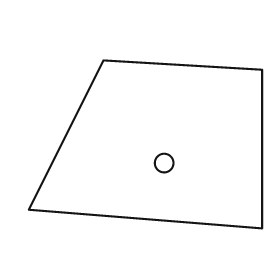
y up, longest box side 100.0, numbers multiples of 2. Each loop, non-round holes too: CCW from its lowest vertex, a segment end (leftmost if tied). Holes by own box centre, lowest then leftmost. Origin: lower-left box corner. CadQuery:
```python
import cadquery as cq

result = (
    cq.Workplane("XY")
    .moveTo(100.0, 0.0)
    .lineTo(100.0, 68.0)
    .lineTo(32.0, 72.0)
    .lineTo(0.0, 8.0)
    .close()
    .moveTo(58.0, 28.0)
    .circle(4.0)
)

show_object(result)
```